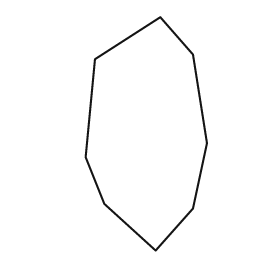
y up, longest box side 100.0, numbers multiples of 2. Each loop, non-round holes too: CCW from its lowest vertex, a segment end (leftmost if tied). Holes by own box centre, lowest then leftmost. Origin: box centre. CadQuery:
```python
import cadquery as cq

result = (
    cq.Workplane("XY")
    .moveTo(4.0, -50.0)
    .lineTo(20.0, -32.0)
    .lineTo(26.0, -4.0)
    .lineTo(20.0, 34.0)
    .lineTo(6.0, 50.0)
    .lineTo(-22.0, 32.0)
    .lineTo(-26.0, -10.0)
    .lineTo(-18.0, -30.0)
    .close()
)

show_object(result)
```